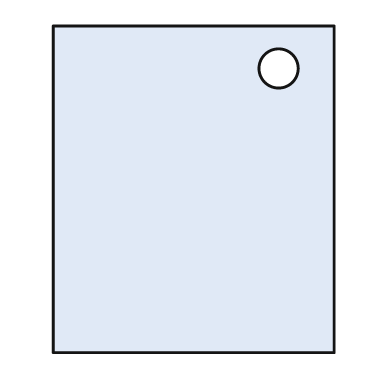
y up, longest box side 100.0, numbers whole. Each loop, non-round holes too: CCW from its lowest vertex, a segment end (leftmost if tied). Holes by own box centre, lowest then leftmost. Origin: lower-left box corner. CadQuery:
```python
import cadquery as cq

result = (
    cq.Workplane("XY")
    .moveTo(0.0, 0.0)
    .lineTo(86.0, 0.0)
    .lineTo(86.0, 100.0)
    .lineTo(0.0, 100.0)
    .close()
    .moveTo(69.0, 87.0)
    .circle(6.0)
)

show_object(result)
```